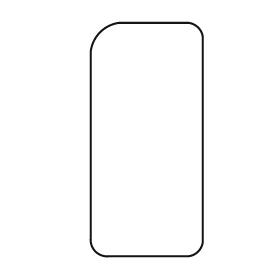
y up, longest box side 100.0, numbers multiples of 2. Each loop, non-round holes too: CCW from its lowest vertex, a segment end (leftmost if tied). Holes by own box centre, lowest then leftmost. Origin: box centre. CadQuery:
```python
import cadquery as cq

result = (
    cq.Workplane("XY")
    .moveTo(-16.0, -50.0)
    .lineTo(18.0, -50.0)
    .threePointArc((22.0, -48.0), (24.0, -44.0))
    .lineTo(24.0, 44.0)
    .threePointArc((22.0, 48.0), (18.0, 50.0))
    .lineTo(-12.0, 50.0)
    .threePointArc((-20.0, 46.0), (-24.0, 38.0))
    .lineTo(-24.0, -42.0)
    .threePointArc((-22.0, -48.0), (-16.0, -50.0))
    .close()
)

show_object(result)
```